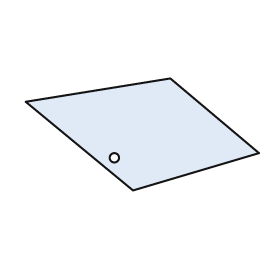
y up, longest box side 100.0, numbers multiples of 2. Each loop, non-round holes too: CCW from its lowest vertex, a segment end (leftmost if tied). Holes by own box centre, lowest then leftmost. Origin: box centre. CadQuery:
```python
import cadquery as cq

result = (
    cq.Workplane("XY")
    .moveTo(-4.0, -24.0)
    .lineTo(50.0, -8.0)
    .lineTo(12.0, 24.0)
    .lineTo(-50.0, 14.0)
    .close()
    .moveTo(-12.0, -10.0)
    .circle(2.0)
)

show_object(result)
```